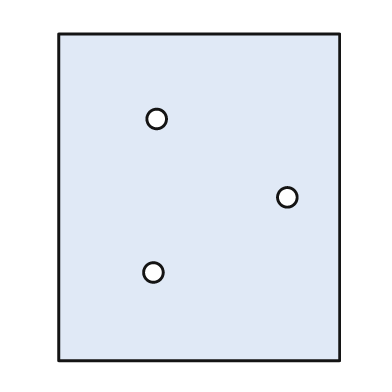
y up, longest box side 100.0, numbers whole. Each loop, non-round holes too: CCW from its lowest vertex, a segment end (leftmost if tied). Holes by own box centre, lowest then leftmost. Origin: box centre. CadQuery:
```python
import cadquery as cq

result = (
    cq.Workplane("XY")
    .moveTo(-43.0, -50.0)
    .lineTo(43.0, -50.0)
    .lineTo(43.0, 50.0)
    .lineTo(-43.0, 50.0)
    .close()
    .moveTo(-14.0, -23.0)
    .circle(3.0)
    .moveTo(27.0, 0.0)
    .circle(3.0)
    .moveTo(-13.0, 24.0)
    .circle(3.0)
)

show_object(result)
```